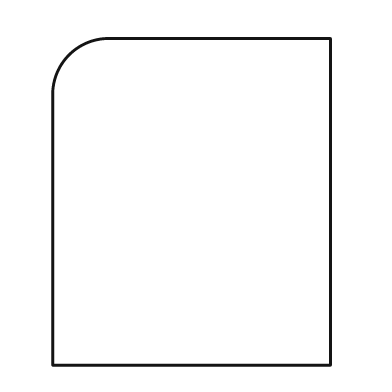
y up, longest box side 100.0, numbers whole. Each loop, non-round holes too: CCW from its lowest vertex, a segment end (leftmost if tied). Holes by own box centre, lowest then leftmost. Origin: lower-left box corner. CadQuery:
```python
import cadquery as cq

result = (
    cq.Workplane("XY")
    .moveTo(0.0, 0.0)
    .lineTo(85.0, 0.0)
    .lineTo(85.0, 100.0)
    .lineTo(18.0, 100.0)
    .threePointArc((5.0, 95.0), (0.0, 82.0))
    .close()
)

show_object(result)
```